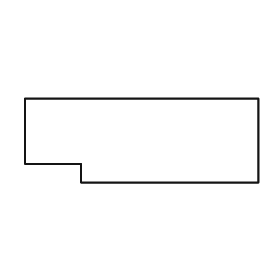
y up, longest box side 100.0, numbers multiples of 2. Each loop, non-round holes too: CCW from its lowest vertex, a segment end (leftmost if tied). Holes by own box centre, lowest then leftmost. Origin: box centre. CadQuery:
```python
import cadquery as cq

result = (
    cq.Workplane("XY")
    .moveTo(-26.0, -18.0)
    .lineTo(50.0, -18.0)
    .lineTo(50.0, 18.0)
    .lineTo(-50.0, 18.0)
    .lineTo(-50.0, -10.0)
    .lineTo(-26.0, -10.0)
    .close()
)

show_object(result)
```